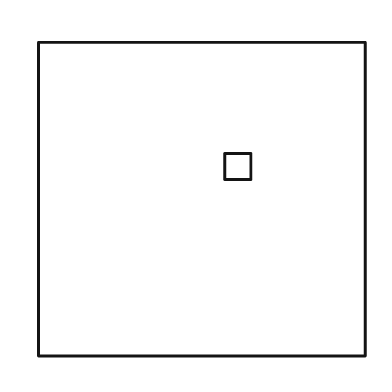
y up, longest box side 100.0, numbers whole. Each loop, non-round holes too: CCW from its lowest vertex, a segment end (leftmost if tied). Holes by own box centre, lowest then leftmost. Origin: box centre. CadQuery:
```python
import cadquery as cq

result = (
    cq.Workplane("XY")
    .moveTo(-50.0, -48.0)
    .lineTo(50.0, -48.0)
    .lineTo(50.0, 48.0)
    .lineTo(-50.0, 48.0)
    .close()
    .moveTo(7.0, 6.0)
    .lineTo(15.0, 6.0)
    .lineTo(15.0, 14.0)
    .lineTo(7.0, 14.0)
    .close()
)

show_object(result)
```